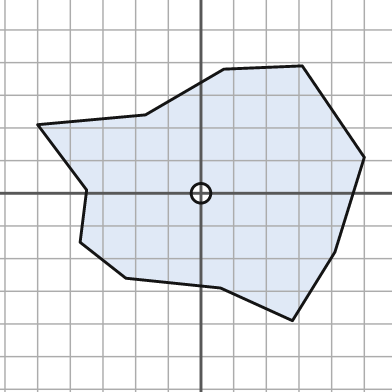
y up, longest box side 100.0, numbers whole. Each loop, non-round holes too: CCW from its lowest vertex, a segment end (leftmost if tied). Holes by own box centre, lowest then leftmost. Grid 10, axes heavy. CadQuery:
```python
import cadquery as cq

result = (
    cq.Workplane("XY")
    .moveTo(28.0, -39.0)
    .lineTo(41.0, -18.0)
    .lineTo(50.0, 11.0)
    .lineTo(31.0, 39.0)
    .lineTo(7.0, 38.0)
    .lineTo(-17.0, 24.0)
    .lineTo(-50.0, 21.0)
    .lineTo(-35.0, 1.0)
    .lineTo(-37.0, -15.0)
    .lineTo(-23.0, -26.0)
    .lineTo(6.0, -29.0)
    .close()
    .moveTo(0.0, 0.0)
    .circle(3.0)
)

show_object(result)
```